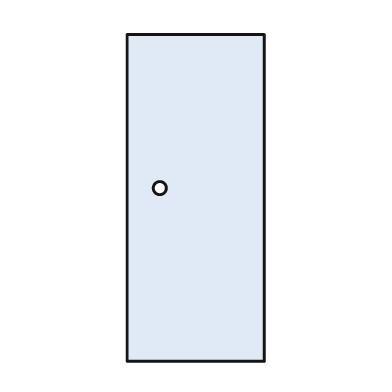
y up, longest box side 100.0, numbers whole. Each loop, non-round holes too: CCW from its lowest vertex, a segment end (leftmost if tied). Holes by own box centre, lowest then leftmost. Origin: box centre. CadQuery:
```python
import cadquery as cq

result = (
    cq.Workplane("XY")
    .moveTo(-21.0, -50.0)
    .lineTo(21.0, -50.0)
    .lineTo(21.0, 50.0)
    .lineTo(-21.0, 50.0)
    .close()
    .moveTo(-11.0, 3.0)
    .circle(2.0)
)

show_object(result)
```